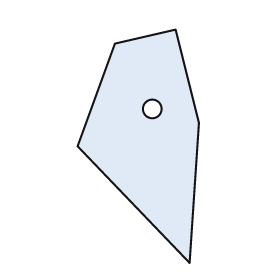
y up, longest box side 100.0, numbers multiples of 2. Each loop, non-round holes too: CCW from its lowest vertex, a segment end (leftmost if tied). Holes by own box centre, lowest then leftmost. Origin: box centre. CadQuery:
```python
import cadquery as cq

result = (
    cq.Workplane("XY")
    .moveTo(22.0, -50.0)
    .lineTo(26.0, 10.0)
    .lineTo(16.0, 50.0)
    .lineTo(-10.0, 44.0)
    .lineTo(-26.0, 0.0)
    .close()
    .moveTo(6.0, 16.0)
    .circle(4.0)
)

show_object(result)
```